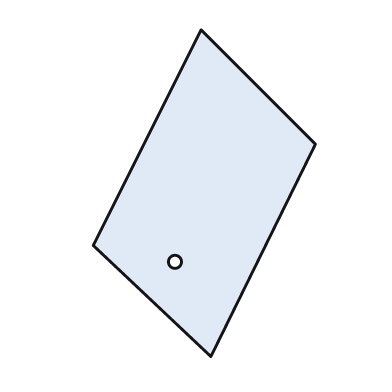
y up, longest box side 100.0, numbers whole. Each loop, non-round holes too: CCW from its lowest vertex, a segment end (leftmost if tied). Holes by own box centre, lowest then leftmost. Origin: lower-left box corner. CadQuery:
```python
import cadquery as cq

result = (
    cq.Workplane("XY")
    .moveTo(36.0, 0.0)
    .lineTo(68.0, 65.0)
    .lineTo(33.0, 100.0)
    .lineTo(0.0, 34.0)
    .close()
    .moveTo(25.0, 29.0)
    .circle(2.0)
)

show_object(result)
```